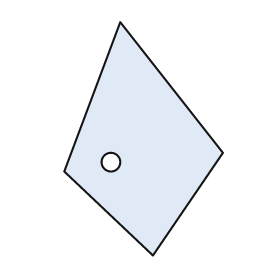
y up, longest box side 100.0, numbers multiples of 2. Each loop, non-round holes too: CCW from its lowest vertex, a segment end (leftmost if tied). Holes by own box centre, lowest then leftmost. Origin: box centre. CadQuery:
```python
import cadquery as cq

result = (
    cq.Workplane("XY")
    .moveTo(4.0, -50.0)
    .lineTo(34.0, -6.0)
    .lineTo(-10.0, 50.0)
    .lineTo(-34.0, -14.0)
    .close()
    .moveTo(-14.0, -10.0)
    .circle(4.0)
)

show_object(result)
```